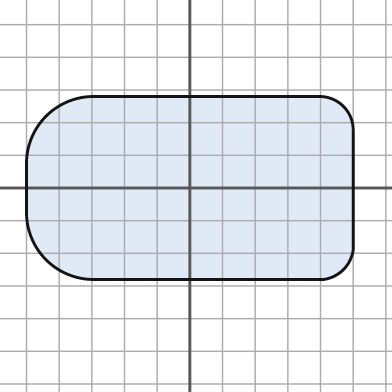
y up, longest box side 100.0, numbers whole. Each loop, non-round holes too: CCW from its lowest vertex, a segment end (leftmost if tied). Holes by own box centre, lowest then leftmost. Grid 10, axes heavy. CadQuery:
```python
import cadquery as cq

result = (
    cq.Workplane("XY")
    .moveTo(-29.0, -28.0)
    .lineTo(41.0, -28.0)
    .threePointArc((47.0, -25.0), (50.0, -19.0))
    .lineTo(50.0, 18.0)
    .threePointArc((47.0, 25.0), (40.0, 28.0))
    .lineTo(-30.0, 28.0)
    .threePointArc((-44.0, 22.0), (-50.0, 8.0))
    .lineTo(-50.0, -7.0)
    .threePointArc((-44.0, -22.0), (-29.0, -28.0))
    .close()
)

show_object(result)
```